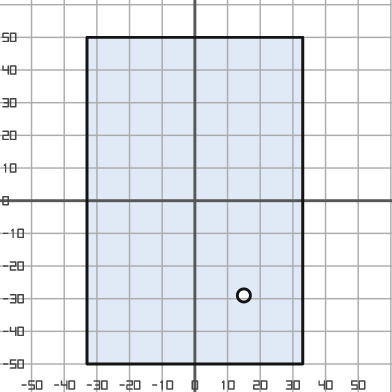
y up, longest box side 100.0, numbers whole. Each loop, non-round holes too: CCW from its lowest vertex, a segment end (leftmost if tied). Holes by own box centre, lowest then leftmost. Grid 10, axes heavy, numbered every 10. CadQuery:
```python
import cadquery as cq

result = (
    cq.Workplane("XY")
    .moveTo(-33.0, -50.0)
    .lineTo(33.0, -50.0)
    .lineTo(33.0, 50.0)
    .lineTo(-33.0, 50.0)
    .close()
    .moveTo(15.0, -29.0)
    .circle(2.0)
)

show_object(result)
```